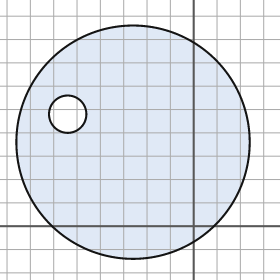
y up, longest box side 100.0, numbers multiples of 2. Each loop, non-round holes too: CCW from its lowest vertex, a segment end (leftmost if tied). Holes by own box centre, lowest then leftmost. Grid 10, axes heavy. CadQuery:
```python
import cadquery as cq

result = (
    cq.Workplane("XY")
    .moveTo(-26.0, 36.0)
    .circle(50.0)
    .moveTo(-54.0, 48.0)
    .circle(8.0)
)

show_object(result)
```